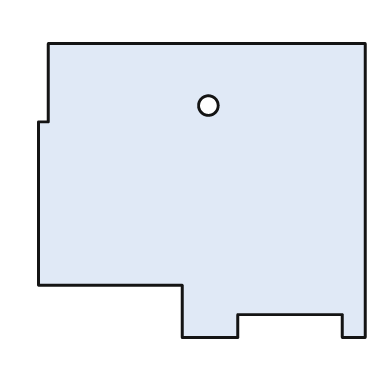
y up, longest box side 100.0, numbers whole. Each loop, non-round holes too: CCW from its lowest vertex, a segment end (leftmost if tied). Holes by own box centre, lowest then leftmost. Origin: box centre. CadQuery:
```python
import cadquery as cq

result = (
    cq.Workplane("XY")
    .moveTo(-6.0, -45.0)
    .lineTo(11.0, -45.0)
    .lineTo(11.0, -38.0)
    .lineTo(43.0, -38.0)
    .lineTo(43.0, -45.0)
    .lineTo(50.0, -45.0)
    .lineTo(50.0, 45.0)
    .lineTo(-47.0, 45.0)
    .lineTo(-47.0, 21.0)
    .lineTo(-50.0, 21.0)
    .lineTo(-50.0, -29.0)
    .lineTo(-6.0, -29.0)
    .close()
    .moveTo(2.0, 26.0)
    .circle(3.0)
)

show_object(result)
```